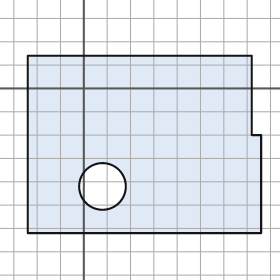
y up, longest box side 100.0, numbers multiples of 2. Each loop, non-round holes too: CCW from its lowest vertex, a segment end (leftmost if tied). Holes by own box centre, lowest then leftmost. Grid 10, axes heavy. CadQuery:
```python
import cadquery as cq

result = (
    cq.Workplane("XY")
    .moveTo(-24.0, -62.0)
    .lineTo(76.0, -62.0)
    .lineTo(76.0, -20.0)
    .lineTo(72.0, -20.0)
    .lineTo(72.0, 14.0)
    .lineTo(-24.0, 14.0)
    .close()
    .moveTo(8.0, -42.0)
    .circle(10.0)
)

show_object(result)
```